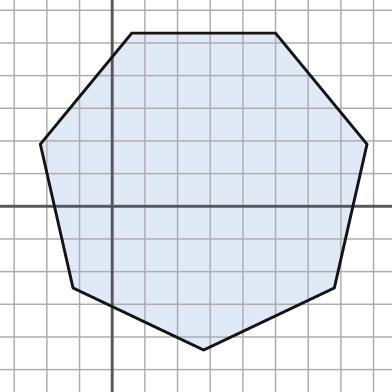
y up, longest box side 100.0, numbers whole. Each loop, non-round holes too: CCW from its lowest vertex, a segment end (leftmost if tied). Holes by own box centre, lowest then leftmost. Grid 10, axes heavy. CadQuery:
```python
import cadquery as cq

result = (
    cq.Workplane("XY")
    .moveTo(28.0, -44.0)
    .lineTo(68.0, -25.0)
    .lineTo(78.0, 19.0)
    .lineTo(50.0, 53.0)
    .lineTo(6.0, 53.0)
    .lineTo(-22.0, 19.0)
    .lineTo(-12.0, -25.0)
    .close()
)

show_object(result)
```